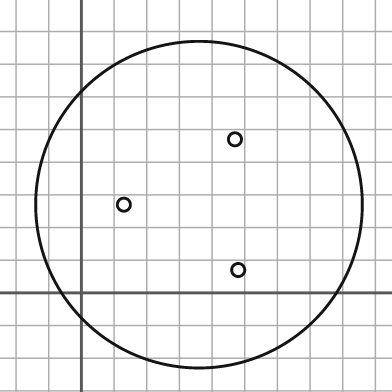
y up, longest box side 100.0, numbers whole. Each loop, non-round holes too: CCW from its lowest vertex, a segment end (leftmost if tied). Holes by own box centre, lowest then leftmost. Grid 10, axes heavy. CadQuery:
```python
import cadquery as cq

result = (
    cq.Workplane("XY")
    .moveTo(36.0, 27.0)
    .circle(50.0)
    .moveTo(48.0, 7.0)
    .circle(2.0)
    .moveTo(13.0, 27.0)
    .circle(2.0)
    .moveTo(47.0, 47.0)
    .circle(2.0)
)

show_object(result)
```